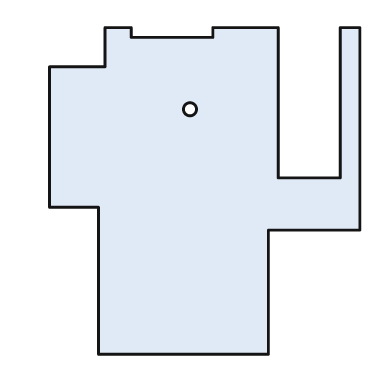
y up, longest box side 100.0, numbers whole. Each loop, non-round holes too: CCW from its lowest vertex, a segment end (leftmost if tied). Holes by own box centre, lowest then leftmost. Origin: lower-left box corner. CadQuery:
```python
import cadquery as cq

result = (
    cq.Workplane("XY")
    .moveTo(15.0, 0.0)
    .lineTo(67.0, 0.0)
    .lineTo(67.0, 38.0)
    .lineTo(95.0, 38.0)
    .lineTo(95.0, 100.0)
    .lineTo(89.0, 100.0)
    .lineTo(89.0, 54.0)
    .lineTo(70.0, 54.0)
    .lineTo(70.0, 100.0)
    .lineTo(50.0, 100.0)
    .lineTo(50.0, 97.0)
    .lineTo(25.0, 97.0)
    .lineTo(25.0, 100.0)
    .lineTo(17.0, 100.0)
    .lineTo(17.0, 88.0)
    .lineTo(0.0, 88.0)
    .lineTo(0.0, 45.0)
    .lineTo(15.0, 45.0)
    .close()
    .moveTo(43.0, 75.0)
    .circle(2.0)
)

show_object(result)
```